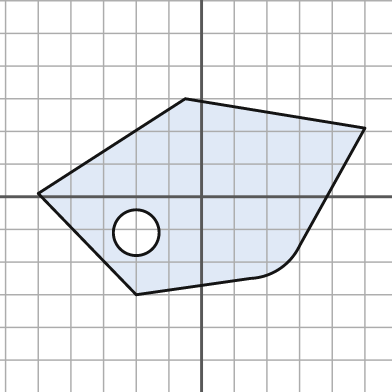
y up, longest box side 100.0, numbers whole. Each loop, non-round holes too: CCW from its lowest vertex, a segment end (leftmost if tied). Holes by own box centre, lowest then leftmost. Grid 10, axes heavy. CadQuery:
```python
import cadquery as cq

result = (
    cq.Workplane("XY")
    .moveTo(-20.0, -30.0)
    .lineTo(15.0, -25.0)
    .threePointArc((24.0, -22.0), (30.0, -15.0))
    .lineTo(50.0, 21.0)
    .lineTo(-5.0, 30.0)
    .lineTo(-50.0, 1.0)
    .close()
    .moveTo(-20.0, -11.0)
    .circle(7.0)
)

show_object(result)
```